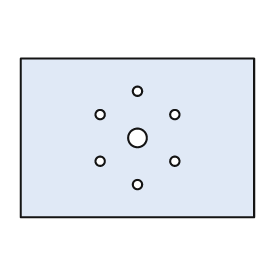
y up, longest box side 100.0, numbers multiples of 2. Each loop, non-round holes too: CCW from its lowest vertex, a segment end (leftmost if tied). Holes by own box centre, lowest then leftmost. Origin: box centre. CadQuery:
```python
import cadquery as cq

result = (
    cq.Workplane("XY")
    .moveTo(-50.0, -34.0)
    .lineTo(50.0, -34.0)
    .lineTo(50.0, 34.0)
    .lineTo(-50.0, 34.0)
    .close()
    .moveTo(0.0, -20.0)
    .circle(2.0)
    .moveTo(-16.0, -10.0)
    .circle(2.0)
    .moveTo(16.0, -10.0)
    .circle(2.0)
    .moveTo(0.0, 0.0)
    .circle(4.0)
    .moveTo(-16.0, 10.0)
    .circle(2.0)
    .moveTo(16.0, 10.0)
    .circle(2.0)
    .moveTo(0.0, 20.0)
    .circle(2.0)
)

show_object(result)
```